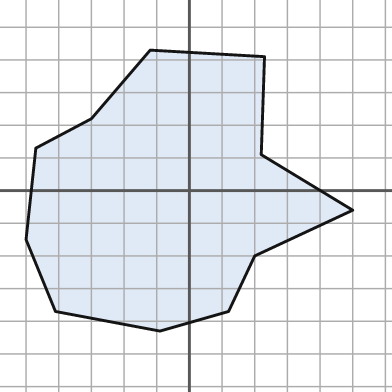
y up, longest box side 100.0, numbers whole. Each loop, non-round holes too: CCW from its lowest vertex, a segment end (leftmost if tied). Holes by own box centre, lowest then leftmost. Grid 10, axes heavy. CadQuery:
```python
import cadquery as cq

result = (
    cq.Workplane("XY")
    .moveTo(-9.0, -43.0)
    .lineTo(12.0, -37.0)
    .lineTo(20.0, -20.0)
    .lineTo(50.0, -6.0)
    .lineTo(22.0, 11.0)
    .lineTo(23.0, 41.0)
    .lineTo(-12.0, 43.0)
    .lineTo(-30.0, 22.0)
    .lineTo(-47.0, 13.0)
    .lineTo(-50.0, -15.0)
    .lineTo(-41.0, -37.0)
    .close()
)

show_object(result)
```